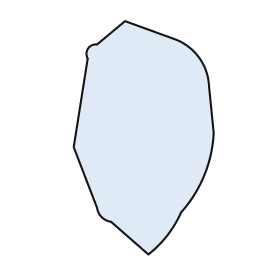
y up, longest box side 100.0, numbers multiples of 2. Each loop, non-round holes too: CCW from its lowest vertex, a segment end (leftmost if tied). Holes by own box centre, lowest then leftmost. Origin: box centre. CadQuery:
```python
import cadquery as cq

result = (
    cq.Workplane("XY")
    .moveTo(2.0, -50.0)
    .threePointArc((10.0, -42.0), (16.0, -32.0))
    .threePointArc((26.0, -16.0), (30.0, 2.0))
    .lineTo(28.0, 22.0)
    .threePointArc((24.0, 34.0), (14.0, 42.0))
    .lineTo(-8.0, 50.0)
    .lineTo(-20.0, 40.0)
    .threePointArc((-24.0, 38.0), (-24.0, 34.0))
    .lineTo(-30.0, -4.0)
    .lineTo(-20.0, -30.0)
    .threePointArc((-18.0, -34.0), (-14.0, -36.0))
    .close()
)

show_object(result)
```